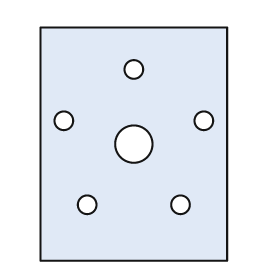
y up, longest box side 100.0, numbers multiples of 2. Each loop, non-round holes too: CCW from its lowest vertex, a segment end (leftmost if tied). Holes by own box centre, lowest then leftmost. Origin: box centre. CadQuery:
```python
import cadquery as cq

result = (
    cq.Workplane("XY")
    .moveTo(-40.0, -50.0)
    .lineTo(40.0, -50.0)
    .lineTo(40.0, 50.0)
    .lineTo(-40.0, 50.0)
    .close()
    .moveTo(-20.0, -26.0)
    .circle(4.0)
    .moveTo(20.0, -26.0)
    .circle(4.0)
    .moveTo(0.0, 0.0)
    .circle(8.0)
    .moveTo(-30.0, 10.0)
    .circle(4.0)
    .moveTo(30.0, 10.0)
    .circle(4.0)
    .moveTo(0.0, 32.0)
    .circle(4.0)
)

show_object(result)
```